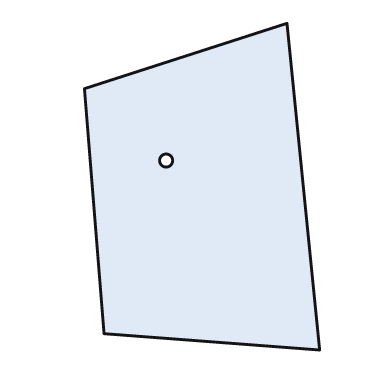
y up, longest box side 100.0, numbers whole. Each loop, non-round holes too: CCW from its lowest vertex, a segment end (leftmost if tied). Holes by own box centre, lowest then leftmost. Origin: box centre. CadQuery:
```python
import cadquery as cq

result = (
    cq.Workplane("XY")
    .moveTo(36.0, -50.0)
    .lineTo(26.0, 50.0)
    .lineTo(-36.0, 30.0)
    .lineTo(-30.0, -45.0)
    .close()
    .moveTo(-11.0, 8.0)
    .circle(2.0)
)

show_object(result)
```